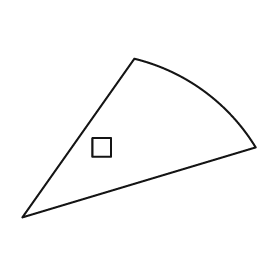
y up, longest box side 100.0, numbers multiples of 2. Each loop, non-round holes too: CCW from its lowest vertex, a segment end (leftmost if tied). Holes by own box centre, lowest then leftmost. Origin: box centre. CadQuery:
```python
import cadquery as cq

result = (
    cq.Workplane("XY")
    .moveTo(-50.0, -34.0)
    .lineTo(50.0, -4.0)
    .threePointArc((28.0, 20.0), (-2.0, 34.0))
    .close()
    .moveTo(-20.0, -8.0)
    .lineTo(-12.0, -8.0)
    .lineTo(-12.0, 0.0)
    .lineTo(-20.0, 0.0)
    .close()
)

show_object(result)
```